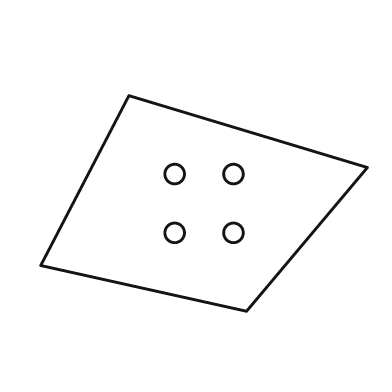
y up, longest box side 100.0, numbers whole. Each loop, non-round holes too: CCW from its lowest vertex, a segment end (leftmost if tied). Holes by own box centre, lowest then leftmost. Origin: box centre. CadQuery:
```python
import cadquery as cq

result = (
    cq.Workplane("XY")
    .moveTo(13.0, -33.0)
    .lineTo(50.0, 11.0)
    .lineTo(-23.0, 33.0)
    .lineTo(-50.0, -19.0)
    .close()
    .moveTo(-9.0, -9.0)
    .circle(3.0)
    .moveTo(9.0, -9.0)
    .circle(3.0)
    .moveTo(-9.0, 9.0)
    .circle(3.0)
    .moveTo(9.0, 9.0)
    .circle(3.0)
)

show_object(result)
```